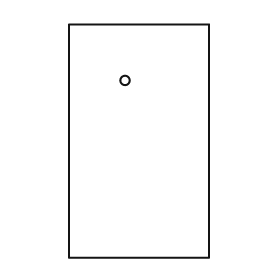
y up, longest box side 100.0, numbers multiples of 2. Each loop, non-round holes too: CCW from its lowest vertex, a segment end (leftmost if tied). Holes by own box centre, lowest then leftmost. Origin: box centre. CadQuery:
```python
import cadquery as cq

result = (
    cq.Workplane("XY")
    .moveTo(-30.0, -50.0)
    .lineTo(30.0, -50.0)
    .lineTo(30.0, 50.0)
    .lineTo(-30.0, 50.0)
    .close()
    .moveTo(-6.0, 26.0)
    .circle(2.0)
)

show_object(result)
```